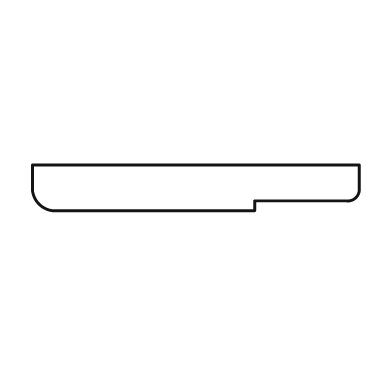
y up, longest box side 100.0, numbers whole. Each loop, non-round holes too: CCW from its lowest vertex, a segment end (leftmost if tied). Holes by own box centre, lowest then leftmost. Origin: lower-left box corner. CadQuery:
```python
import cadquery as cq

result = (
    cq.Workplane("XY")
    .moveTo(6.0, 0.0)
    .lineTo(68.0, 0.0)
    .lineTo(68.0, 3.0)
    .lineTo(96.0, 3.0)
    .threePointArc((99.0, 4.0), (100.0, 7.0))
    .lineTo(100.0, 14.0)
    .lineTo(0.0, 14.0)
    .lineTo(0.0, 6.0)
    .threePointArc((2.0, 2.0), (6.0, 0.0))
    .close()
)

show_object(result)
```